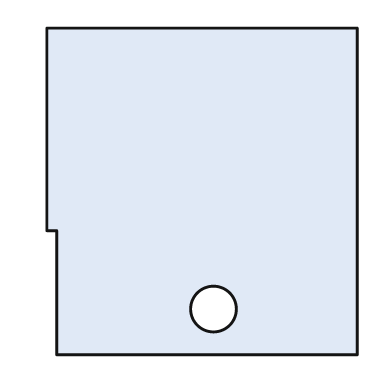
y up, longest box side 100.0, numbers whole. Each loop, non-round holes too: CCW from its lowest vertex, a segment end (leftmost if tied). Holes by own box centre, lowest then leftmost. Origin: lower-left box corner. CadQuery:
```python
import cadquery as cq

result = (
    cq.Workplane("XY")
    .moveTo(3.0, 0.0)
    .lineTo(95.0, 0.0)
    .lineTo(95.0, 100.0)
    .lineTo(0.0, 100.0)
    .lineTo(0.0, 38.0)
    .lineTo(3.0, 38.0)
    .close()
    .moveTo(51.0, 14.0)
    .circle(7.0)
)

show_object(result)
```